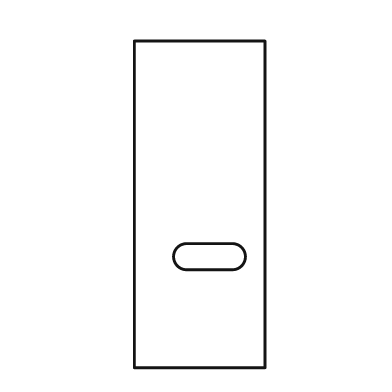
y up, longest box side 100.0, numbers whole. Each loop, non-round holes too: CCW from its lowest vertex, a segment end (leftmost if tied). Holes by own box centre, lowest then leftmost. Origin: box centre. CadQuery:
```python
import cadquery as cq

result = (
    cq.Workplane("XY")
    .moveTo(-20.0, -50.0)
    .lineTo(20.0, -50.0)
    .lineTo(20.0, 50.0)
    .lineTo(-20.0, 50.0)
    .close()
    .moveTo(-4.0, -20.0)
    .lineTo(10.0, -20.0)
    .threePointArc((14.0, -16.0), (10.0, -12.0))
    .lineTo(-4.0, -12.0)
    .threePointArc((-8.0, -16.0), (-4.0, -20.0))
    .close()
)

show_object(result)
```